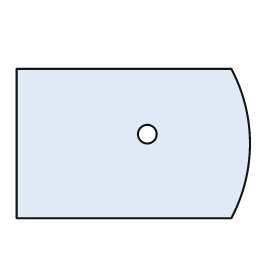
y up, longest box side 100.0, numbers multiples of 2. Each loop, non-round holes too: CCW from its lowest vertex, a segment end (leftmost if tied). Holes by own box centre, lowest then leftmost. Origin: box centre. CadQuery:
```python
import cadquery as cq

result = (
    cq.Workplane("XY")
    .moveTo(-50.0, -32.0)
    .lineTo(42.0, -32.0)
    .threePointArc((50.0, 0.0), (42.0, 32.0))
    .lineTo(-50.0, 32.0)
    .close()
    .moveTo(6.0, 4.0)
    .circle(4.0)
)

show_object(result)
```